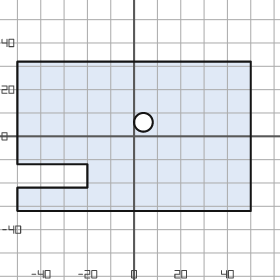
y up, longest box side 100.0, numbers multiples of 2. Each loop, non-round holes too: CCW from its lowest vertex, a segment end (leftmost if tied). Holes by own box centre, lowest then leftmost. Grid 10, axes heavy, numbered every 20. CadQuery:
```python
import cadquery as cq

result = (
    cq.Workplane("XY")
    .moveTo(-50.0, -32.0)
    .lineTo(50.0, -32.0)
    .lineTo(50.0, 32.0)
    .lineTo(-50.0, 32.0)
    .lineTo(-50.0, -12.0)
    .lineTo(-20.0, -12.0)
    .lineTo(-20.0, -22.0)
    .lineTo(-50.0, -22.0)
    .close()
    .moveTo(4.0, 6.0)
    .circle(4.0)
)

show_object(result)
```